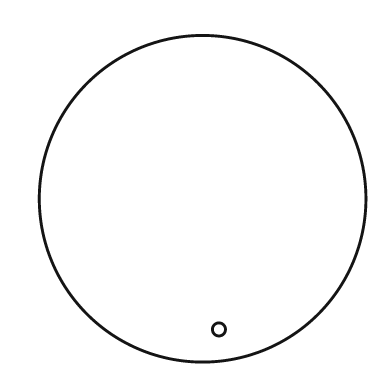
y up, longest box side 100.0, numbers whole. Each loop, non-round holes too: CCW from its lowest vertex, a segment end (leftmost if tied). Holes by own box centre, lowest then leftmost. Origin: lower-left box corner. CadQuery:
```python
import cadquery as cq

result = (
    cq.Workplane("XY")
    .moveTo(50.0, 50.0)
    .circle(50.0)
    .moveTo(55.0, 10.0)
    .circle(2.0)
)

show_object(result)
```